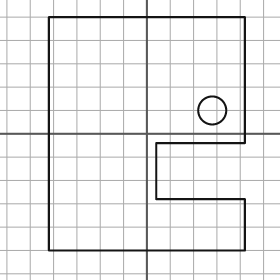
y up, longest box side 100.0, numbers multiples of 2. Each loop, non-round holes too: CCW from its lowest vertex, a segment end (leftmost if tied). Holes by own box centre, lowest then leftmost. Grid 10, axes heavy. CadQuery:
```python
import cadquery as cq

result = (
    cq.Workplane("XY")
    .moveTo(-42.0, -50.0)
    .lineTo(42.0, -50.0)
    .lineTo(42.0, -28.0)
    .lineTo(4.0, -28.0)
    .lineTo(4.0, -4.0)
    .lineTo(42.0, -4.0)
    .lineTo(42.0, 50.0)
    .lineTo(-42.0, 50.0)
    .close()
    .moveTo(28.0, 10.0)
    .circle(6.0)
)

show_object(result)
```